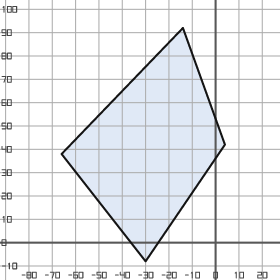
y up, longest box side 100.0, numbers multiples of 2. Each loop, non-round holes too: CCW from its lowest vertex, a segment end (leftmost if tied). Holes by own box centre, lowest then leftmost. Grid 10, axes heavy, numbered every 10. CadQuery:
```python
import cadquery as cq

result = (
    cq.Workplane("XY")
    .moveTo(-30.0, -8.0)
    .lineTo(4.0, 42.0)
    .lineTo(-14.0, 92.0)
    .lineTo(-66.0, 38.0)
    .close()
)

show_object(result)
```